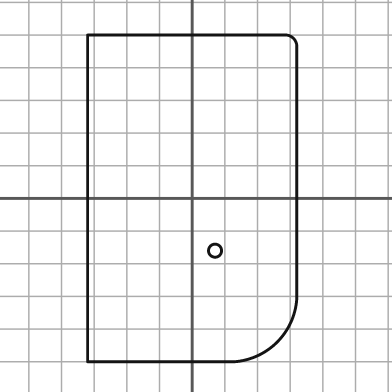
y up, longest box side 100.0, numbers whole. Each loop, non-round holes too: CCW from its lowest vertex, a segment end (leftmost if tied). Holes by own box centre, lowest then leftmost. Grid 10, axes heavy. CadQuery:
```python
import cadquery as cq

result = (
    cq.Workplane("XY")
    .moveTo(-32.0, -50.0)
    .lineTo(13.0, -50.0)
    .threePointArc((26.0, -44.0), (32.0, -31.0))
    .lineTo(32.0, 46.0)
    .threePointArc((31.0, 49.0), (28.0, 50.0))
    .lineTo(-32.0, 50.0)
    .close()
    .moveTo(7.0, -16.0)
    .circle(2.0)
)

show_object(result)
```